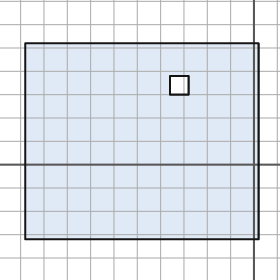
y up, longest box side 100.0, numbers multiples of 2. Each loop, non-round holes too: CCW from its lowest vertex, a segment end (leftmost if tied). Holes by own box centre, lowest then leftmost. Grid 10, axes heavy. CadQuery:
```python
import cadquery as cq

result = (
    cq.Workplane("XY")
    .moveTo(-98.0, -32.0)
    .lineTo(2.0, -32.0)
    .lineTo(2.0, 52.0)
    .lineTo(-98.0, 52.0)
    .close()
    .moveTo(-36.0, 30.0)
    .lineTo(-28.0, 30.0)
    .lineTo(-28.0, 38.0)
    .lineTo(-36.0, 38.0)
    .close()
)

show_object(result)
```